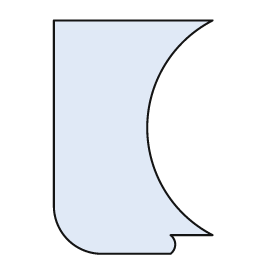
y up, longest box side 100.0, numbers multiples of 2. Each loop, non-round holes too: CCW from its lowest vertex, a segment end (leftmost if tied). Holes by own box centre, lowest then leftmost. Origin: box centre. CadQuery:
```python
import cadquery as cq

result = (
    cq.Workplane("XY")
    .moveTo(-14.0, -50.0)
    .lineTo(16.0, -50.0)
    .threePointArc((18.0, -46.0), (16.0, -42.0))
    .lineTo(34.0, -42.0)
    .threePointArc((6.0, 4.0), (34.0, 50.0))
    .lineTo(-34.0, 50.0)
    .lineTo(-34.0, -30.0)
    .threePointArc((-28.0, -44.0), (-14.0, -50.0))
    .close()
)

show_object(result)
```